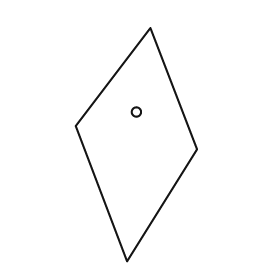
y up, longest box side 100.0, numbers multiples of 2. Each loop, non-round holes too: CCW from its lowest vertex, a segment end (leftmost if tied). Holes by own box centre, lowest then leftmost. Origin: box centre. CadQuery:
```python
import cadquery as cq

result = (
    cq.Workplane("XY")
    .moveTo(-4.0, -50.0)
    .lineTo(26.0, -2.0)
    .lineTo(6.0, 50.0)
    .lineTo(-26.0, 8.0)
    .close()
    .moveTo(0.0, 14.0)
    .circle(2.0)
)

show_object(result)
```